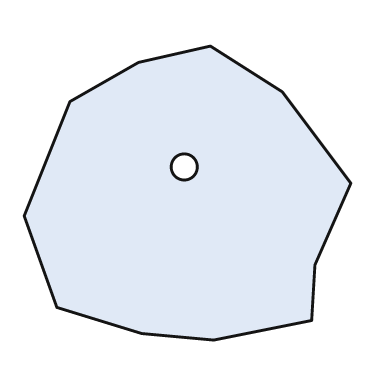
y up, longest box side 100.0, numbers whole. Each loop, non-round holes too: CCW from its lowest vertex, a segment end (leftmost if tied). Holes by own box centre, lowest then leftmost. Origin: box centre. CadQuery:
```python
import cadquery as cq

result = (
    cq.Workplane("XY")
    .moveTo(8.0, -45.0)
    .lineTo(38.0, -39.0)
    .lineTo(39.0, -22.0)
    .lineTo(50.0, 3.0)
    .lineTo(29.0, 31.0)
    .lineTo(7.0, 45.0)
    .lineTo(-15.0, 40.0)
    .lineTo(-36.0, 28.0)
    .lineTo(-50.0, -7.0)
    .lineTo(-40.0, -35.0)
    .lineTo(-14.0, -43.0)
    .close()
    .moveTo(-1.0, 8.0)
    .circle(4.0)
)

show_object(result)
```